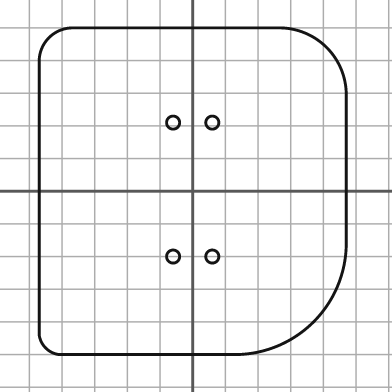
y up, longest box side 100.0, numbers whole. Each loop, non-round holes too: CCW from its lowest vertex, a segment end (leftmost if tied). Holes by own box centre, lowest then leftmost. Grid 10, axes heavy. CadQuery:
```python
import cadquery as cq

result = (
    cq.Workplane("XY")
    .moveTo(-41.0, -50.0)
    .lineTo(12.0, -50.0)
    .threePointArc((37.0, -40.0), (47.0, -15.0))
    .lineTo(47.0, 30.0)
    .threePointArc((41.0, 44.0), (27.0, 50.0))
    .lineTo(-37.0, 50.0)
    .threePointArc((-44.0, 47.0), (-47.0, 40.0))
    .lineTo(-47.0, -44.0)
    .threePointArc((-45.0, -48.0), (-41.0, -50.0))
    .close()
    .moveTo(-6.0, -20.0)
    .circle(2.0)
    .moveTo(6.0, -20.0)
    .circle(2.0)
    .moveTo(-6.0, 21.0)
    .circle(2.0)
    .moveTo(6.0, 21.0)
    .circle(2.0)
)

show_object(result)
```